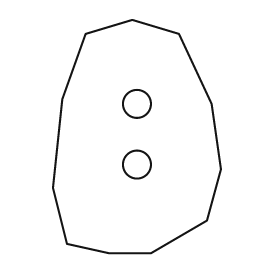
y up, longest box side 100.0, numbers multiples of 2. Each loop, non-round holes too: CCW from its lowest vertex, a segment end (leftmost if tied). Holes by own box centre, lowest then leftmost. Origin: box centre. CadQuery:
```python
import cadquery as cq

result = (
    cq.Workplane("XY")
    .moveTo(-12.0, -50.0)
    .lineTo(6.0, -50.0)
    .lineTo(30.0, -36.0)
    .lineTo(36.0, -14.0)
    .lineTo(32.0, 14.0)
    .lineTo(18.0, 44.0)
    .lineTo(-2.0, 50.0)
    .lineTo(-22.0, 44.0)
    .lineTo(-32.0, 16.0)
    .lineTo(-36.0, -22.0)
    .lineTo(-30.0, -46.0)
    .close()
    .moveTo(0.0, -12.0)
    .circle(6.0)
    .moveTo(0.0, 14.0)
    .circle(6.0)
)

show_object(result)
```